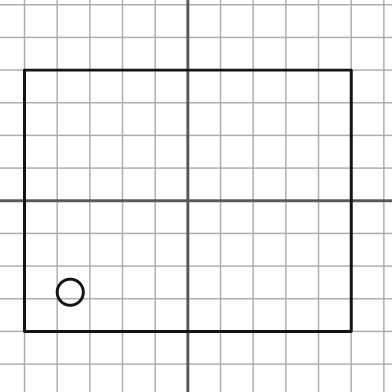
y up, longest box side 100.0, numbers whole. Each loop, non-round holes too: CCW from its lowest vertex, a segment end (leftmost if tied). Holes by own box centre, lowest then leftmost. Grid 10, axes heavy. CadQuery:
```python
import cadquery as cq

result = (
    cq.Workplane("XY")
    .moveTo(-50.0, -40.0)
    .lineTo(50.0, -40.0)
    .lineTo(50.0, 40.0)
    .lineTo(-50.0, 40.0)
    .close()
    .moveTo(-36.0, -28.0)
    .circle(4.0)
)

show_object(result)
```